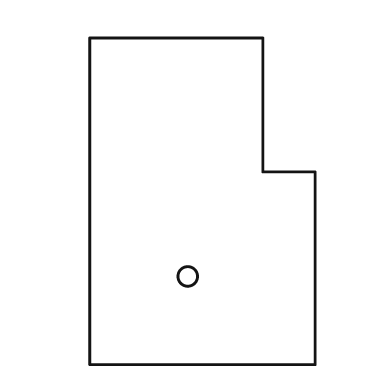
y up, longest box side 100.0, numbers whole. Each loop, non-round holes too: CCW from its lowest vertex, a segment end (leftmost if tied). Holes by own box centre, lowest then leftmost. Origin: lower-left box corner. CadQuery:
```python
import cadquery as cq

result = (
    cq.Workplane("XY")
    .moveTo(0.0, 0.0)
    .lineTo(69.0, 0.0)
    .lineTo(69.0, 59.0)
    .lineTo(53.0, 59.0)
    .lineTo(53.0, 100.0)
    .lineTo(0.0, 100.0)
    .close()
    .moveTo(30.0, 27.0)
    .circle(3.0)
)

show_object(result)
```